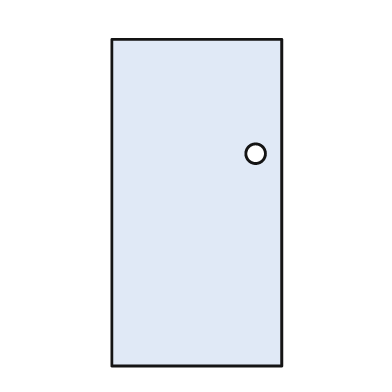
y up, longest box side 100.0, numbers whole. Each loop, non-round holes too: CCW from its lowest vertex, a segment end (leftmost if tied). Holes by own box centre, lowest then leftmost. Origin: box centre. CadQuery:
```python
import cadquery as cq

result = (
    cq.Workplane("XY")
    .moveTo(-26.0, -50.0)
    .lineTo(26.0, -50.0)
    .lineTo(26.0, 50.0)
    .lineTo(-26.0, 50.0)
    .close()
    .moveTo(18.0, 15.0)
    .circle(3.0)
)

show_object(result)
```